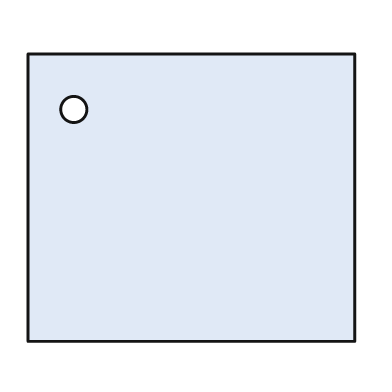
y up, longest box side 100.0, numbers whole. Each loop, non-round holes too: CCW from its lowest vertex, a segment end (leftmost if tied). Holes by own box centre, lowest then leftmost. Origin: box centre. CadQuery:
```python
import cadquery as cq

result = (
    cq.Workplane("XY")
    .moveTo(-50.0, -44.0)
    .lineTo(50.0, -44.0)
    .lineTo(50.0, 44.0)
    .lineTo(-50.0, 44.0)
    .close()
    .moveTo(-36.0, 27.0)
    .circle(4.0)
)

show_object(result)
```